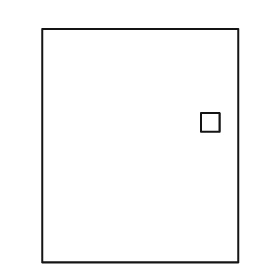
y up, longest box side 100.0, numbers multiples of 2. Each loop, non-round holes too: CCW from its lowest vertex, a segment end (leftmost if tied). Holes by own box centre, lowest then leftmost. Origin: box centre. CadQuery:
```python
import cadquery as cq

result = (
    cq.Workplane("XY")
    .moveTo(-42.0, -50.0)
    .lineTo(42.0, -50.0)
    .lineTo(42.0, 50.0)
    .lineTo(-42.0, 50.0)
    .close()
    .moveTo(26.0, 6.0)
    .lineTo(34.0, 6.0)
    .lineTo(34.0, 14.0)
    .lineTo(26.0, 14.0)
    .close()
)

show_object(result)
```